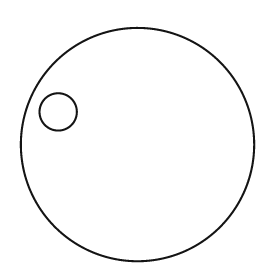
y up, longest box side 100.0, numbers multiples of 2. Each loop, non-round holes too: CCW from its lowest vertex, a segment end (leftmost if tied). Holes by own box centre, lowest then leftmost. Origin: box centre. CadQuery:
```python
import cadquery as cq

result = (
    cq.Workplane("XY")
    .moveTo(0.0, 0.0)
    .circle(50.0)
    .moveTo(-34.0, 14.0)
    .circle(8.0)
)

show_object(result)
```